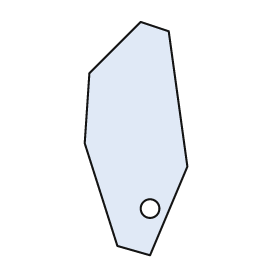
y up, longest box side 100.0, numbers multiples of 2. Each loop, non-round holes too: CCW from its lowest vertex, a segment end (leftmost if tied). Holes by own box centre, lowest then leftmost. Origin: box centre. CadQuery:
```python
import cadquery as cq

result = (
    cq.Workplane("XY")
    .moveTo(6.0, -50.0)
    .lineTo(22.0, -12.0)
    .lineTo(14.0, 46.0)
    .lineTo(2.0, 50.0)
    .lineTo(-20.0, 28.0)
    .lineTo(-22.0, -2.0)
    .lineTo(-8.0, -46.0)
    .close()
    .moveTo(6.0, -30.0)
    .circle(4.0)
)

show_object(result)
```